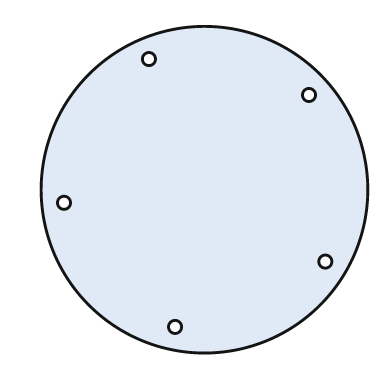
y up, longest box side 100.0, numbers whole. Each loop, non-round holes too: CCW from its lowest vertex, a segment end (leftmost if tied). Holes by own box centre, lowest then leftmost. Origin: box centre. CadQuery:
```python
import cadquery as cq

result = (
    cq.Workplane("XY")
    .moveTo(0.0, 0.0)
    .circle(50.0)
    .moveTo(-9.0, -42.0)
    .circle(2.0)
    .moveTo(37.0, -22.0)
    .circle(2.0)
    .moveTo(-43.0, -4.0)
    .circle(2.0)
    .moveTo(32.0, 29.0)
    .circle(2.0)
    .moveTo(-17.0, 40.0)
    .circle(2.0)
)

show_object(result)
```